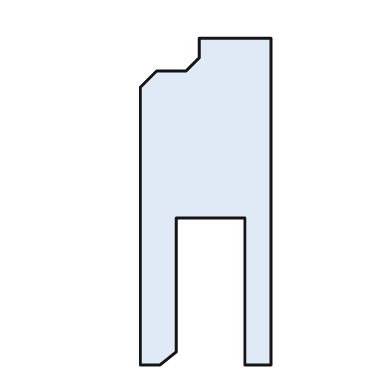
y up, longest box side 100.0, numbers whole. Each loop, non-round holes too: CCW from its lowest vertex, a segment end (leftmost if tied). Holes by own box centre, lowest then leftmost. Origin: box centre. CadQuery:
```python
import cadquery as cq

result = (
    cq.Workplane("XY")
    .moveTo(-20.0, -50.0)
    .lineTo(-14.0, -50.0)
    .lineTo(-9.0, -46.0)
    .lineTo(-9.0, -5.0)
    .lineTo(12.0, -5.0)
    .lineTo(12.0, -50.0)
    .lineTo(20.0, -50.0)
    .lineTo(20.0, 50.0)
    .lineTo(-2.0, 50.0)
    .lineTo(-2.0, 44.0)
    .lineTo(-6.0, 40.0)
    .lineTo(-15.0, 40.0)
    .lineTo(-20.0, 35.0)
    .close()
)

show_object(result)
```